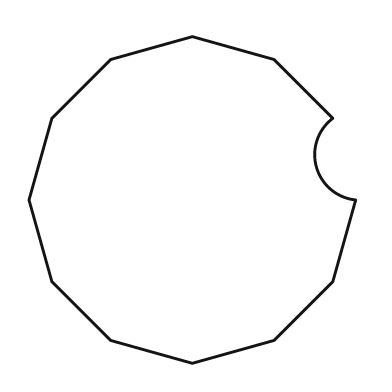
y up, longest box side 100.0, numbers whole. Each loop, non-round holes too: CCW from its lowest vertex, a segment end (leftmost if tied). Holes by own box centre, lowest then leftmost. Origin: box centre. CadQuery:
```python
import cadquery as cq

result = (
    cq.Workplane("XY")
    .moveTo(0.0, -50.0)
    .lineTo(25.0, -43.0)
    .lineTo(43.0, -25.0)
    .lineTo(50.0, 0.0)
    .threePointArc((38.0, 10.0), (43.0, 25.0))
    .lineTo(25.0, 43.0)
    .lineTo(0.0, 50.0)
    .lineTo(-25.0, 43.0)
    .lineTo(-43.0, 25.0)
    .lineTo(-50.0, 0.0)
    .lineTo(-43.0, -25.0)
    .lineTo(-25.0, -43.0)
    .close()
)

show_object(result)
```